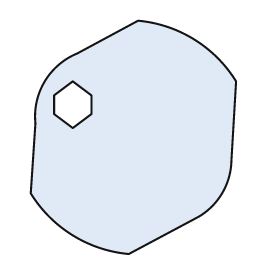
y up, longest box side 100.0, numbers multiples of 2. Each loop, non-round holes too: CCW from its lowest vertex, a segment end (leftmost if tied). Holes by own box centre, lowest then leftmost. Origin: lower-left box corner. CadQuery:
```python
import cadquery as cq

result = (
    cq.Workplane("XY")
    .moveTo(42.0, 0.0)
    .lineTo(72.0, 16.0)
    .threePointArc((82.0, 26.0), (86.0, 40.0))
    .lineTo(88.0, 74.0)
    .threePointArc((70.0, 92.0), (46.0, 100.0))
    .lineTo(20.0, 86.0)
    .threePointArc((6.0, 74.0), (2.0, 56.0))
    .lineTo(0.0, 26.0)
    .threePointArc((18.0, 8.0), (42.0, 0.0))
    .close()
    .moveTo(18.0, 54.0)
    .lineTo(26.0, 60.0)
    .lineTo(26.0, 68.0)
    .lineTo(18.0, 74.0)
    .lineTo(10.0, 68.0)
    .lineTo(10.0, 60.0)
    .close()
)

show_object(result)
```